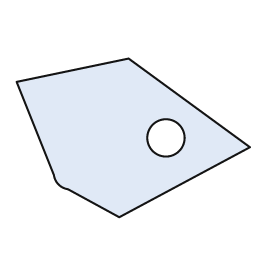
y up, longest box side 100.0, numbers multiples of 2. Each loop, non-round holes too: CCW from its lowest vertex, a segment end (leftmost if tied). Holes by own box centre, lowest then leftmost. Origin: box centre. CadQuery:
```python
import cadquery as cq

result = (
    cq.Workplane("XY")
    .moveTo(-6.0, -34.0)
    .lineTo(50.0, -4.0)
    .lineTo(-2.0, 34.0)
    .lineTo(-50.0, 24.0)
    .lineTo(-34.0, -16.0)
    .threePointArc((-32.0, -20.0), (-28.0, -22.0))
    .close()
    .moveTo(14.0, 0.0)
    .circle(8.0)
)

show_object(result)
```